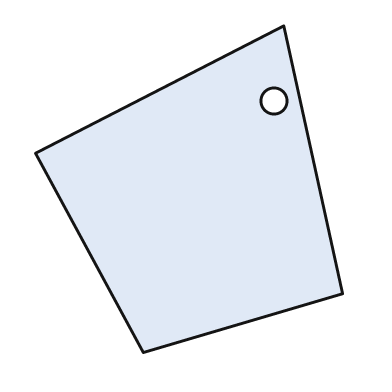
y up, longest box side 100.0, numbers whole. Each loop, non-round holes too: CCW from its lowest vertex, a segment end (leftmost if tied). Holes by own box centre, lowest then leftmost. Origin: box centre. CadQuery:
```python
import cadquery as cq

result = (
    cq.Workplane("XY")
    .moveTo(-14.0, -50.0)
    .lineTo(47.0, -32.0)
    .lineTo(29.0, 50.0)
    .lineTo(-47.0, 11.0)
    .close()
    .moveTo(26.0, 27.0)
    .circle(4.0)
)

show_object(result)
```